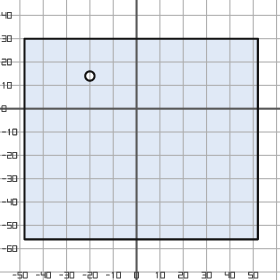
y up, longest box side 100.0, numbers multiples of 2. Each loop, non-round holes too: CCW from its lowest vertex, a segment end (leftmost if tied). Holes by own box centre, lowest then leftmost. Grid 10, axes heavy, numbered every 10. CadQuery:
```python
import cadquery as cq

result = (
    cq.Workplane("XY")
    .moveTo(-48.0, -56.0)
    .lineTo(52.0, -56.0)
    .lineTo(52.0, 30.0)
    .lineTo(-48.0, 30.0)
    .close()
    .moveTo(-20.0, 14.0)
    .circle(2.0)
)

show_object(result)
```